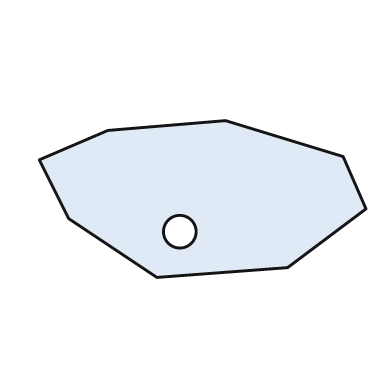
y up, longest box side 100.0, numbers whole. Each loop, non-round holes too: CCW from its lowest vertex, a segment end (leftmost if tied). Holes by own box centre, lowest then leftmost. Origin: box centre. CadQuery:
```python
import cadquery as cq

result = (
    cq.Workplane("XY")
    .moveTo(-14.0, -24.0)
    .lineTo(26.0, -21.0)
    .lineTo(50.0, -3.0)
    .lineTo(43.0, 13.0)
    .lineTo(7.0, 24.0)
    .lineTo(-29.0, 21.0)
    .lineTo(-50.0, 12.0)
    .lineTo(-41.0, -6.0)
    .close()
    .moveTo(-7.0, -10.0)
    .circle(5.0)
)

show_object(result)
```